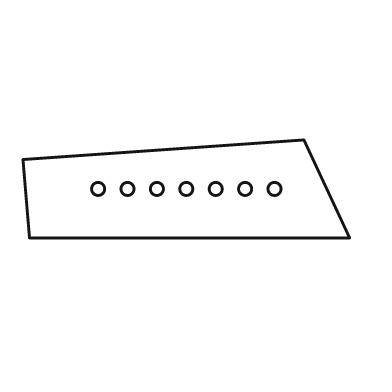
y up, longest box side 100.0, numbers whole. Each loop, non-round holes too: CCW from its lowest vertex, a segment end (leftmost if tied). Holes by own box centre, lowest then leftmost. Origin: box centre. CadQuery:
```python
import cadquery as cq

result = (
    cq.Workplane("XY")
    .moveTo(-48.0, -15.0)
    .lineTo(50.0, -15.0)
    .lineTo(36.0, 15.0)
    .lineTo(-50.0, 9.0)
    .close()
    .moveTo(-27.0, 0.0)
    .circle(2.0)
    .moveTo(-18.0, 0.0)
    .circle(2.0)
    .moveTo(-9.0, 0.0)
    .circle(2.0)
    .moveTo(0.0, 0.0)
    .circle(2.0)
    .moveTo(9.0, 0.0)
    .circle(2.0)
    .moveTo(18.0, 0.0)
    .circle(2.0)
    .moveTo(27.0, 0.0)
    .circle(2.0)
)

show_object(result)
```